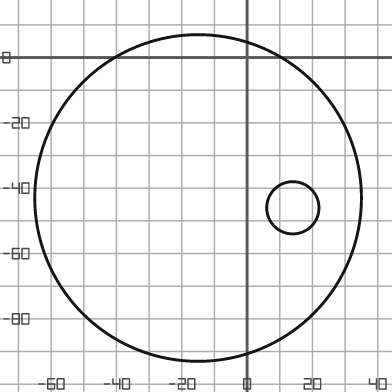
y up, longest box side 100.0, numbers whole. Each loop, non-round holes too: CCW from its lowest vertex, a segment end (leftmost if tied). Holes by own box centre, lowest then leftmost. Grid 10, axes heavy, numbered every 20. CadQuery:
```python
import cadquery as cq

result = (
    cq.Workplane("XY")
    .moveTo(-15.0, -43.0)
    .circle(50.0)
    .moveTo(14.0, -46.0)
    .circle(8.0)
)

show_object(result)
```